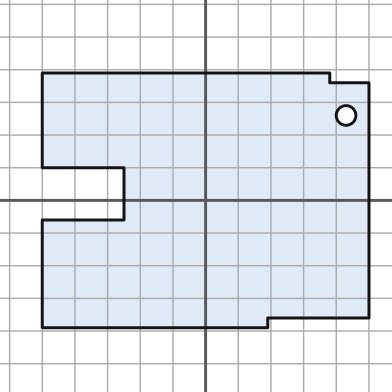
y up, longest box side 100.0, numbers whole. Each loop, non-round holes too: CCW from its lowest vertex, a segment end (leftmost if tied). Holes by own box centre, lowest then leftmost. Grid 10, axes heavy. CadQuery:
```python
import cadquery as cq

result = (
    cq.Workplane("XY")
    .moveTo(-50.0, -39.0)
    .lineTo(19.0, -39.0)
    .lineTo(19.0, -36.0)
    .lineTo(50.0, -36.0)
    .lineTo(50.0, 36.0)
    .lineTo(38.0, 36.0)
    .lineTo(38.0, 39.0)
    .lineTo(-50.0, 39.0)
    .lineTo(-50.0, 10.0)
    .lineTo(-25.0, 10.0)
    .lineTo(-25.0, -6.0)
    .lineTo(-50.0, -6.0)
    .close()
    .moveTo(43.0, 26.0)
    .circle(3.0)
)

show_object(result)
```